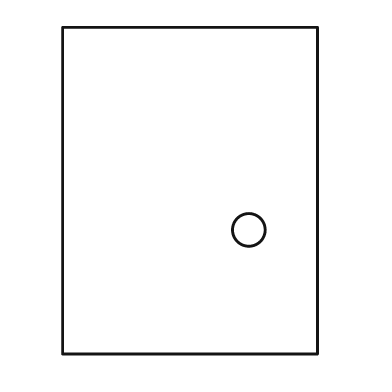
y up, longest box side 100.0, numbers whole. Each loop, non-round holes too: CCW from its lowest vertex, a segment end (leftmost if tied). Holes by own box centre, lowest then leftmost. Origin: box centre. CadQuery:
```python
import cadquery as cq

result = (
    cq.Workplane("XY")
    .moveTo(-39.0, -50.0)
    .lineTo(39.0, -50.0)
    .lineTo(39.0, 50.0)
    .lineTo(-39.0, 50.0)
    .close()
    .moveTo(18.0, -12.0)
    .circle(5.0)
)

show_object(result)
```